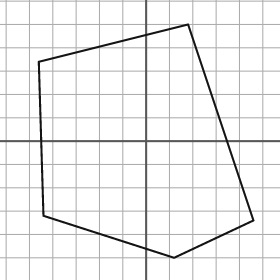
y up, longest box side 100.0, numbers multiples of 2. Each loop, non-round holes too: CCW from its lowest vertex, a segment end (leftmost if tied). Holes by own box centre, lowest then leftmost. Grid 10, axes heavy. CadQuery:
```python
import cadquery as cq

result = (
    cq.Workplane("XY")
    .moveTo(12.0, -50.0)
    .lineTo(46.0, -34.0)
    .lineTo(18.0, 50.0)
    .lineTo(-46.0, 34.0)
    .lineTo(-44.0, -32.0)
    .close()
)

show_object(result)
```